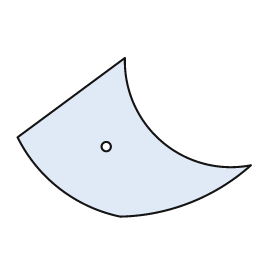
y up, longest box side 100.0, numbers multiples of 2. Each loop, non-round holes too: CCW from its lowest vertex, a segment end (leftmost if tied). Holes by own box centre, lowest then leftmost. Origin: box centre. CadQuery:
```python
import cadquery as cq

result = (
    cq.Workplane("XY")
    .moveTo(-6.0, -34.0)
    .threePointArc((24.0, -28.0), (50.0, -12.0))
    .threePointArc((12.0, -2.0), (-4.0, 34.0))
    .lineTo(-50.0, 0.0)
    .threePointArc((-32.0, -22.0), (-6.0, -34.0))
    .close()
    .moveTo(-12.0, -4.0)
    .circle(2.0)
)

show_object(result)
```